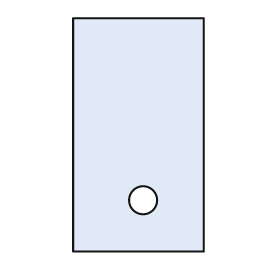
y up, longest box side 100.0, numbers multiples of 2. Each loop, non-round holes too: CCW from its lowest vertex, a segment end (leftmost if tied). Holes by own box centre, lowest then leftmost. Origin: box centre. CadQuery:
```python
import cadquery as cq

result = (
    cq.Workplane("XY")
    .moveTo(-28.0, -50.0)
    .lineTo(28.0, -50.0)
    .lineTo(28.0, 50.0)
    .lineTo(-28.0, 50.0)
    .close()
    .moveTo(2.0, -28.0)
    .circle(6.0)
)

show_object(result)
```